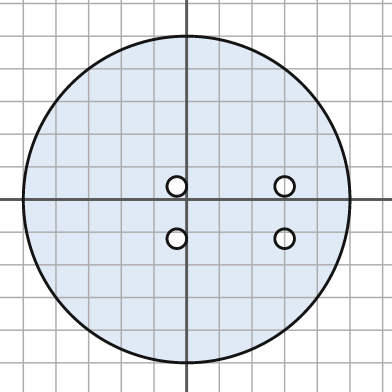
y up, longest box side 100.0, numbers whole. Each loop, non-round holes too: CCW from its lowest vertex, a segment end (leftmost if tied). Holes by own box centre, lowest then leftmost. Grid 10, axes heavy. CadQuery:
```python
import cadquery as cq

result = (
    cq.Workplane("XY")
    .moveTo(0.0, 0.0)
    .circle(50.0)
    .moveTo(-3.0, -12.0)
    .circle(3.0)
    .moveTo(30.0, -12.0)
    .circle(3.0)
    .moveTo(-3.0, 4.0)
    .circle(3.0)
    .moveTo(30.0, 4.0)
    .circle(3.0)
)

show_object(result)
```